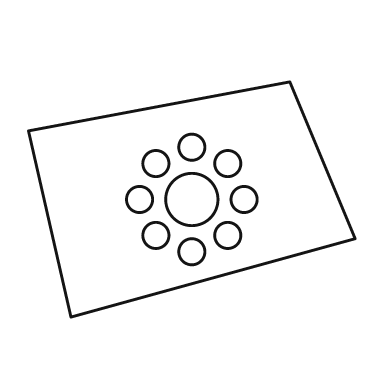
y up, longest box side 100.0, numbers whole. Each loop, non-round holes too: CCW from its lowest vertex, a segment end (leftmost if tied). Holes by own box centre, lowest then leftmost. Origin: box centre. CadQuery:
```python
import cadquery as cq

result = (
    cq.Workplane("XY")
    .moveTo(-37.0, -36.0)
    .lineTo(50.0, -12.0)
    .lineTo(30.0, 36.0)
    .lineTo(-50.0, 21.0)
    .close()
    .moveTo(0.0, -16.0)
    .circle(4.0)
    .moveTo(-11.0, -11.0)
    .circle(4.0)
    .moveTo(11.0, -11.0)
    .circle(4.0)
    .moveTo(-16.0, 0.0)
    .circle(4.0)
    .moveTo(0.0, 0.0)
    .circle(8.0)
    .moveTo(16.0, 0.0)
    .circle(4.0)
    .moveTo(-11.0, 11.0)
    .circle(4.0)
    .moveTo(11.0, 11.0)
    .circle(4.0)
    .moveTo(0.0, 16.0)
    .circle(4.0)
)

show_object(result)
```